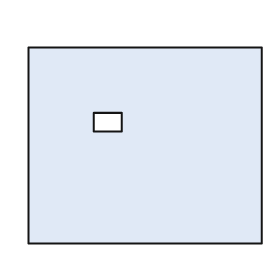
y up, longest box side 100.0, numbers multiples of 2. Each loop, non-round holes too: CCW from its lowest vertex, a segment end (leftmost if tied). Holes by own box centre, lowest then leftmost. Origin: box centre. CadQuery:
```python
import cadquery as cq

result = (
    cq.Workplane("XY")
    .moveTo(-50.0, -42.0)
    .lineTo(50.0, -42.0)
    .lineTo(50.0, 42.0)
    .lineTo(-50.0, 42.0)
    .close()
    .moveTo(-22.0, 6.0)
    .lineTo(-10.0, 6.0)
    .lineTo(-10.0, 14.0)
    .lineTo(-22.0, 14.0)
    .close()
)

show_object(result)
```